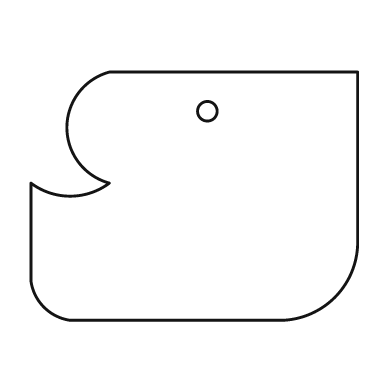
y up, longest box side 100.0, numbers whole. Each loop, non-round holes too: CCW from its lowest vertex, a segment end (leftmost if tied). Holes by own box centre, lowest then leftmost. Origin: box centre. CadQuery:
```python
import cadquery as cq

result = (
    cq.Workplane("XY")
    .moveTo(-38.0, -38.0)
    .lineTo(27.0, -38.0)
    .threePointArc((43.0, -31.0), (50.0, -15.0))
    .lineTo(50.0, 38.0)
    .lineTo(-26.0, 38.0)
    .threePointArc((-39.0, 21.0), (-26.0, 4.0))
    .threePointArc((-38.0, 0.0), (-50.0, 4.0))
    .lineTo(-50.0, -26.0)
    .threePointArc((-46.0, -34.0), (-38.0, -38.0))
    .close()
    .moveTo(4.0, 26.0)
    .circle(3.0)
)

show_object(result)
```